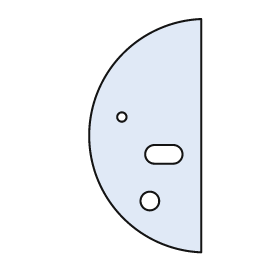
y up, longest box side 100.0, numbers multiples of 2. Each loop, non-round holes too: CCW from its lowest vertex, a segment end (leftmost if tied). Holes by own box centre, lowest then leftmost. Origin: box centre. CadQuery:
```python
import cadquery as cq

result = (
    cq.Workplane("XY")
    .moveTo(24.0, -50.0)
    .lineTo(24.0, 50.0)
    .threePointArc((-24.0, 0.0), (24.0, -50.0))
    .close()
    .moveTo(2.0, -28.0)
    .circle(4.0)
    .moveTo(4.0, -12.0)
    .lineTo(12.0, -12.0)
    .threePointArc((16.0, -8.0), (12.0, -4.0))
    .lineTo(4.0, -4.0)
    .threePointArc((0.0, -8.0), (4.0, -12.0))
    .close()
    .moveTo(-10.0, 8.0)
    .circle(2.0)
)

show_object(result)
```